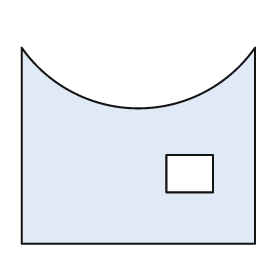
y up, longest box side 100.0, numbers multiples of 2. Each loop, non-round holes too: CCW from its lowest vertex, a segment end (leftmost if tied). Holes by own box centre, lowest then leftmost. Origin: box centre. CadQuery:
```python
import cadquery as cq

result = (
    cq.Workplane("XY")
    .moveTo(-50.0, -42.0)
    .lineTo(50.0, -42.0)
    .lineTo(50.0, 42.0)
    .threePointArc((0.0, 16.0), (-50.0, 42.0))
    .close()
    .moveTo(12.0, -20.0)
    .lineTo(32.0, -20.0)
    .lineTo(32.0, -4.0)
    .lineTo(12.0, -4.0)
    .close()
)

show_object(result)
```